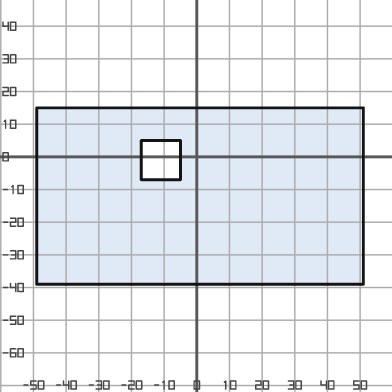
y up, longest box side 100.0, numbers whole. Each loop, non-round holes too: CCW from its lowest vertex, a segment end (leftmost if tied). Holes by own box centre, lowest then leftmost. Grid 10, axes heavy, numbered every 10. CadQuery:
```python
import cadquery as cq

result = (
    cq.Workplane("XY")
    .moveTo(-49.0, -39.0)
    .lineTo(51.0, -39.0)
    .lineTo(51.0, 15.0)
    .lineTo(-49.0, 15.0)
    .close()
    .moveTo(-17.0, -7.0)
    .lineTo(-5.0, -7.0)
    .lineTo(-5.0, 5.0)
    .lineTo(-17.0, 5.0)
    .close()
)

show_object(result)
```